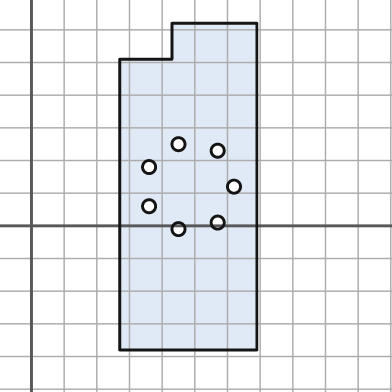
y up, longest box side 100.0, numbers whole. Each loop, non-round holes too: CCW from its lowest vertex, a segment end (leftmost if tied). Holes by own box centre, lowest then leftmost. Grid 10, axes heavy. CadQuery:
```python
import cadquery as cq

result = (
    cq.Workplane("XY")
    .moveTo(27.0, -38.0)
    .lineTo(69.0, -38.0)
    .lineTo(69.0, 62.0)
    .lineTo(43.0, 62.0)
    .lineTo(43.0, 51.0)
    .lineTo(27.0, 51.0)
    .close()
    .moveTo(45.0, -1.0)
    .circle(2.0)
    .moveTo(57.0, 1.0)
    .circle(2.0)
    .moveTo(36.0, 6.0)
    .circle(2.0)
    .moveTo(62.0, 12.0)
    .circle(2.0)
    .moveTo(36.0, 18.0)
    .circle(2.0)
    .moveTo(57.0, 23.0)
    .circle(2.0)
    .moveTo(45.0, 25.0)
    .circle(2.0)
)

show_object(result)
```